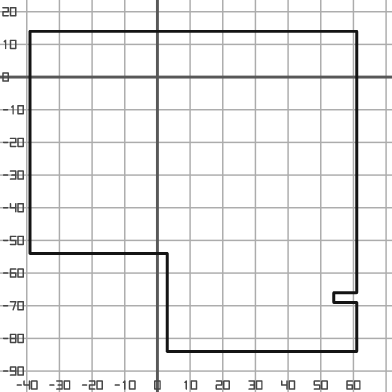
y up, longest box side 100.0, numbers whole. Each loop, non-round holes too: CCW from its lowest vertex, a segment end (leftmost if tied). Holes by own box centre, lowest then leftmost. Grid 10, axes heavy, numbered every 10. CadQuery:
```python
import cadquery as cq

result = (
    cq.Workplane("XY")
    .moveTo(3.0, -84.0)
    .lineTo(61.0, -84.0)
    .lineTo(61.0, -69.0)
    .lineTo(54.0, -69.0)
    .lineTo(54.0, -66.0)
    .lineTo(61.0, -66.0)
    .lineTo(61.0, 14.0)
    .lineTo(-39.0, 14.0)
    .lineTo(-39.0, -54.0)
    .lineTo(3.0, -54.0)
    .close()
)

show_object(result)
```